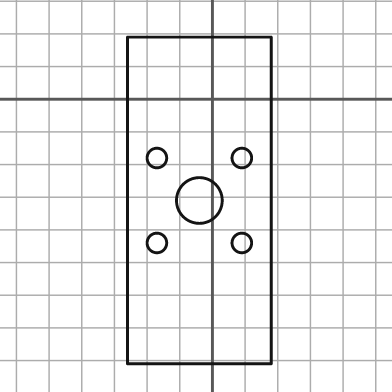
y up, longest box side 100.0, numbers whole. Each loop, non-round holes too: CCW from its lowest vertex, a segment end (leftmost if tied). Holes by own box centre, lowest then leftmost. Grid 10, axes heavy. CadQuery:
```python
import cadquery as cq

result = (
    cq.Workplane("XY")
    .moveTo(-26.0, -81.0)
    .lineTo(18.0, -81.0)
    .lineTo(18.0, 19.0)
    .lineTo(-26.0, 19.0)
    .close()
    .moveTo(-17.0, -44.0)
    .circle(3.0)
    .moveTo(9.0, -44.0)
    .circle(3.0)
    .moveTo(-4.0, -31.0)
    .circle(7.0)
    .moveTo(-17.0, -18.0)
    .circle(3.0)
    .moveTo(9.0, -18.0)
    .circle(3.0)
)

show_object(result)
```